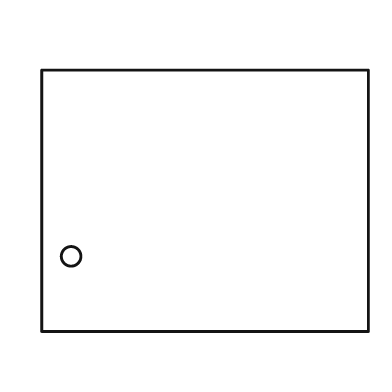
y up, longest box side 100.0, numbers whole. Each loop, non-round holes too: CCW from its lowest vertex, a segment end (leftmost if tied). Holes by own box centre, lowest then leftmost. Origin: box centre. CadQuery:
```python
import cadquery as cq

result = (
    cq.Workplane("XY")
    .moveTo(-50.0, -40.0)
    .lineTo(50.0, -40.0)
    .lineTo(50.0, 40.0)
    .lineTo(-50.0, 40.0)
    .close()
    .moveTo(-41.0, -17.0)
    .circle(3.0)
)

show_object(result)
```